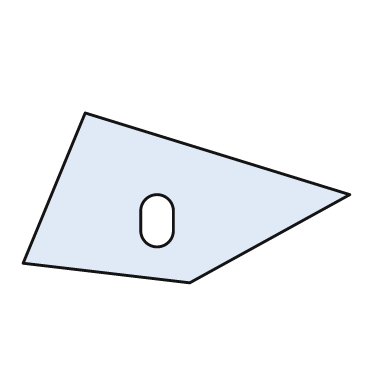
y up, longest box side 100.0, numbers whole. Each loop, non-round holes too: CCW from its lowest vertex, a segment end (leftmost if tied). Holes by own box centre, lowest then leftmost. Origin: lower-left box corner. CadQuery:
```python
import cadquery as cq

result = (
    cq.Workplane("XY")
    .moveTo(51.0, 0.0)
    .lineTo(100.0, 27.0)
    .lineTo(19.0, 52.0)
    .lineTo(0.0, 6.0)
    .close()
    .moveTo(36.0, 16.0)
    .threePointArc((41.0, 11.0), (46.0, 16.0))
    .lineTo(46.0, 22.0)
    .threePointArc((41.0, 27.0), (36.0, 22.0))
    .close()
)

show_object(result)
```